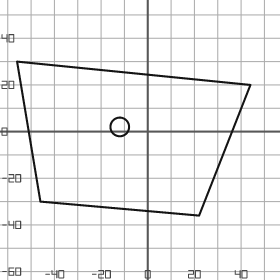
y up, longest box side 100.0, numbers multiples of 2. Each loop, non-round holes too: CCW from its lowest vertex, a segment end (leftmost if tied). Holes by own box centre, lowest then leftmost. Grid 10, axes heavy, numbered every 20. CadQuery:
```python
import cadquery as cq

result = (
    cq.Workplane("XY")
    .moveTo(22.0, -36.0)
    .lineTo(44.0, 20.0)
    .lineTo(-56.0, 30.0)
    .lineTo(-46.0, -30.0)
    .close()
    .moveTo(-12.0, 2.0)
    .circle(4.0)
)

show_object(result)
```